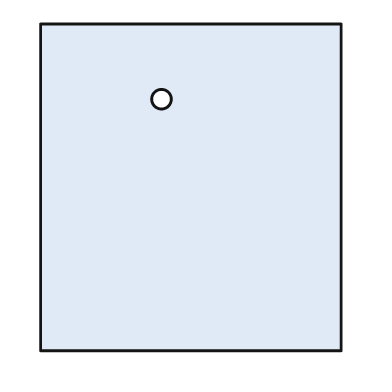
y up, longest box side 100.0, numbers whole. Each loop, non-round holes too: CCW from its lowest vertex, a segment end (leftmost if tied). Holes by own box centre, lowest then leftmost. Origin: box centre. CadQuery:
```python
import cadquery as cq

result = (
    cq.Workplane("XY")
    .moveTo(-46.0, -50.0)
    .lineTo(46.0, -50.0)
    .lineTo(46.0, 50.0)
    .lineTo(-46.0, 50.0)
    .close()
    .moveTo(-9.0, 27.0)
    .circle(3.0)
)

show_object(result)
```